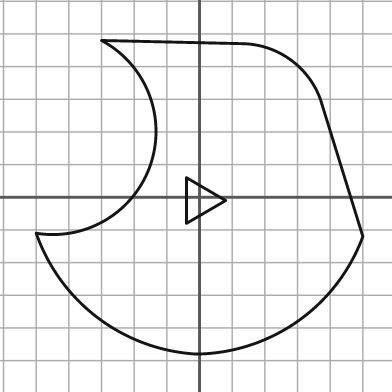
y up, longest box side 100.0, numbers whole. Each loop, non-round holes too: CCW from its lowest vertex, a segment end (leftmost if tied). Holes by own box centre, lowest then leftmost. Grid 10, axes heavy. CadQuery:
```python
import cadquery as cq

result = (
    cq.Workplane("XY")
    .moveTo(-1.0, -48.0)
    .threePointArc((30.0, -38.0), (50.0, -12.0))
    .lineTo(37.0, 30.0)
    .threePointArc((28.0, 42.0), (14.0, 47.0))
    .lineTo(-30.0, 48.0)
    .threePointArc((-15.0, 10.0), (-50.0, -11.0))
    .threePointArc((-31.0, -37.0), (-1.0, -48.0))
    .close()
    .moveTo(-4.0, -8.0)
    .lineTo(8.0, -1.0)
    .lineTo(-4.0, 6.0)
    .close()
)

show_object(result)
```